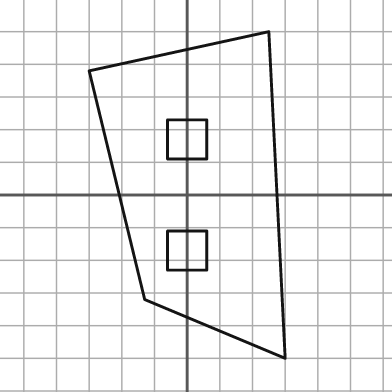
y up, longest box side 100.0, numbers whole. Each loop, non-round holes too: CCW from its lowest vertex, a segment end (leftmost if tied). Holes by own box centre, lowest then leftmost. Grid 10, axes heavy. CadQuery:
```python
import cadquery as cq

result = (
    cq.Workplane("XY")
    .moveTo(30.0, -50.0)
    .lineTo(25.0, 50.0)
    .lineTo(-30.0, 38.0)
    .lineTo(-13.0, -32.0)
    .close()
    .moveTo(-6.0, -23.0)
    .lineTo(6.0, -23.0)
    .lineTo(6.0, -11.0)
    .lineTo(-6.0, -11.0)
    .close()
    .moveTo(-6.0, 11.0)
    .lineTo(6.0, 11.0)
    .lineTo(6.0, 23.0)
    .lineTo(-6.0, 23.0)
    .close()
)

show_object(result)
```